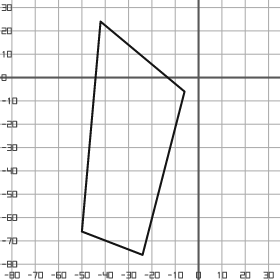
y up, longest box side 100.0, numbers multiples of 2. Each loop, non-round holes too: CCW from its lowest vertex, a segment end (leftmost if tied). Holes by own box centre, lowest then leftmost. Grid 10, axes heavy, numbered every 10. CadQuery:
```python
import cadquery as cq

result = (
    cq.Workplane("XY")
    .moveTo(-24.0, -76.0)
    .lineTo(-6.0, -6.0)
    .lineTo(-42.0, 24.0)
    .lineTo(-50.0, -66.0)
    .close()
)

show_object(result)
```